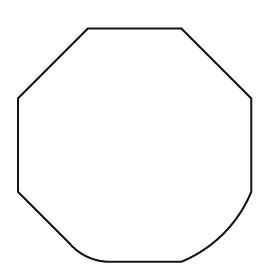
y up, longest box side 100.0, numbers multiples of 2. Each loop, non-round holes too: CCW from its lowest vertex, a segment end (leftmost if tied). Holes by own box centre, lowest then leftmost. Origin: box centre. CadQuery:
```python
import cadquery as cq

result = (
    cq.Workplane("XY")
    .moveTo(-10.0, -50.0)
    .lineTo(20.0, -50.0)
    .threePointArc((38.0, -38.0), (50.0, -20.0))
    .lineTo(50.0, 20.0)
    .lineTo(20.0, 50.0)
    .lineTo(-20.0, 50.0)
    .lineTo(-50.0, 20.0)
    .lineTo(-50.0, -20.0)
    .lineTo(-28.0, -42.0)
    .threePointArc((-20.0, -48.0), (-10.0, -50.0))
    .close()
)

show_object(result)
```